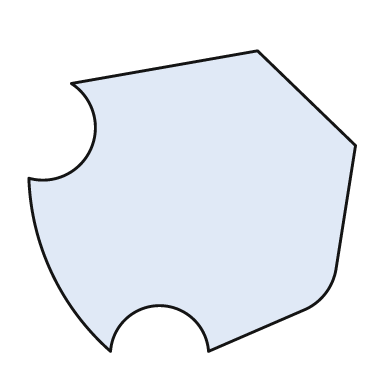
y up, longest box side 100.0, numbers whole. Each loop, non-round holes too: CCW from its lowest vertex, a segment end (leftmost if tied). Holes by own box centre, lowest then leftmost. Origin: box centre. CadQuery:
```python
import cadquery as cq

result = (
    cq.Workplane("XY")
    .moveTo(-25.0, -46.0)
    .threePointArc((-10.0, -32.0), (5.0, -46.0))
    .lineTo(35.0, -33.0)
    .threePointArc((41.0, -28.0), (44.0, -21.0))
    .lineTo(50.0, 17.0)
    .lineTo(20.0, 46.0)
    .lineTo(-37.0, 36.0)
    .threePointArc((-31.0, 16.0), (-50.0, 7.0))
    .threePointArc((-43.0, -22.0), (-25.0, -46.0))
    .close()
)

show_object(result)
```